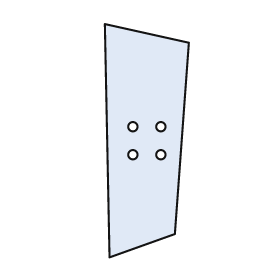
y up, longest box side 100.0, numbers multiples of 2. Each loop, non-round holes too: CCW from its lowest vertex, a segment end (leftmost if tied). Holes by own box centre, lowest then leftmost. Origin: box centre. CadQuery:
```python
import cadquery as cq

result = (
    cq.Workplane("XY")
    .moveTo(-16.0, -50.0)
    .lineTo(12.0, -40.0)
    .lineTo(18.0, 42.0)
    .lineTo(-18.0, 50.0)
    .close()
    .moveTo(-6.0, -6.0)
    .circle(2.0)
    .moveTo(6.0, -6.0)
    .circle(2.0)
    .moveTo(-6.0, 6.0)
    .circle(2.0)
    .moveTo(6.0, 6.0)
    .circle(2.0)
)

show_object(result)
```